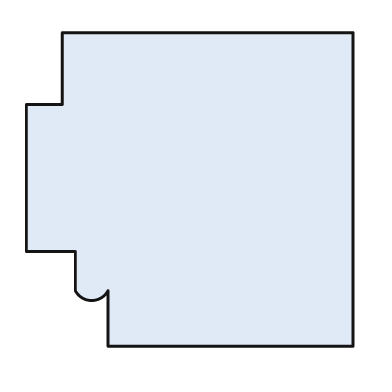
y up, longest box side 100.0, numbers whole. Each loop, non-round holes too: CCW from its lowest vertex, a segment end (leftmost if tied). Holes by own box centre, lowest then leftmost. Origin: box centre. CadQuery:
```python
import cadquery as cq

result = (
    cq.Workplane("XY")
    .moveTo(-25.0, -48.0)
    .lineTo(50.0, -48.0)
    .lineTo(50.0, 48.0)
    .lineTo(-39.0, 48.0)
    .lineTo(-39.0, 26.0)
    .lineTo(-50.0, 26.0)
    .lineTo(-50.0, -19.0)
    .lineTo(-35.0, -19.0)
    .lineTo(-35.0, -31.0)
    .threePointArc((-30.0, -34.0), (-25.0, -31.0))
    .close()
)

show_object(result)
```